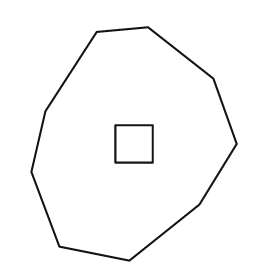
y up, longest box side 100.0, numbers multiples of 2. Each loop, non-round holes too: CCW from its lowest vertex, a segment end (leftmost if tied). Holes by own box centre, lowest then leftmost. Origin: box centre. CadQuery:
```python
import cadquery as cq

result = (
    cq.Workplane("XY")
    .moveTo(-2.0, -50.0)
    .lineTo(28.0, -26.0)
    .lineTo(44.0, 0.0)
    .lineTo(34.0, 28.0)
    .lineTo(6.0, 50.0)
    .lineTo(-16.0, 48.0)
    .lineTo(-38.0, 14.0)
    .lineTo(-44.0, -12.0)
    .lineTo(-32.0, -44.0)
    .close()
    .moveTo(-8.0, -8.0)
    .lineTo(8.0, -8.0)
    .lineTo(8.0, 8.0)
    .lineTo(-8.0, 8.0)
    .close()
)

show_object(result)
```